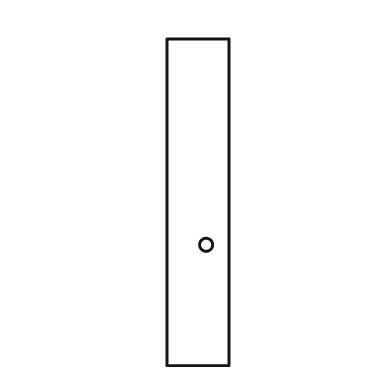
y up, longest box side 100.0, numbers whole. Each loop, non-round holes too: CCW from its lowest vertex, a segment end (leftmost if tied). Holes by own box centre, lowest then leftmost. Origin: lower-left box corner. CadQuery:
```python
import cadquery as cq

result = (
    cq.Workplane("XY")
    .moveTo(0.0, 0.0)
    .lineTo(19.0, 0.0)
    .lineTo(19.0, 100.0)
    .lineTo(0.0, 100.0)
    .close()
    .moveTo(12.0, 37.0)
    .circle(2.0)
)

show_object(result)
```